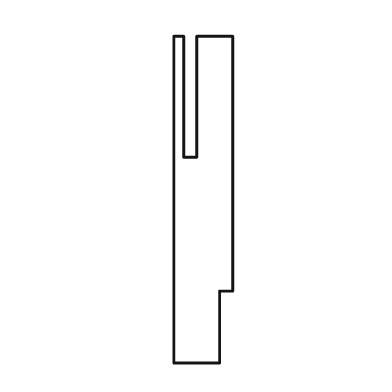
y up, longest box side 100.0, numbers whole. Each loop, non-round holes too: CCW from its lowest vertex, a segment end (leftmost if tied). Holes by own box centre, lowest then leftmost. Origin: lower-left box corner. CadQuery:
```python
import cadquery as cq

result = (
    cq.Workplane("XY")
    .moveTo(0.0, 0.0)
    .lineTo(14.0, 0.0)
    .lineTo(14.0, 22.0)
    .lineTo(18.0, 22.0)
    .lineTo(18.0, 100.0)
    .lineTo(7.0, 100.0)
    .lineTo(7.0, 63.0)
    .lineTo(3.0, 63.0)
    .lineTo(3.0, 100.0)
    .lineTo(0.0, 100.0)
    .close()
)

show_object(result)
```